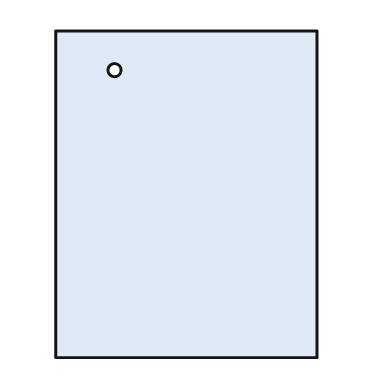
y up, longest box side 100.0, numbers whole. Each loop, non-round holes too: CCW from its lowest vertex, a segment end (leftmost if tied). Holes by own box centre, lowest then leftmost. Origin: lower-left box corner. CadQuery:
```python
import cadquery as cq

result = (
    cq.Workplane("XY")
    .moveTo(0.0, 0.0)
    .lineTo(80.0, 0.0)
    .lineTo(80.0, 100.0)
    .lineTo(0.0, 100.0)
    .close()
    .moveTo(18.0, 88.0)
    .circle(2.0)
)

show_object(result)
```